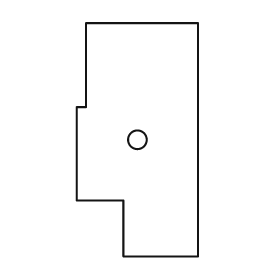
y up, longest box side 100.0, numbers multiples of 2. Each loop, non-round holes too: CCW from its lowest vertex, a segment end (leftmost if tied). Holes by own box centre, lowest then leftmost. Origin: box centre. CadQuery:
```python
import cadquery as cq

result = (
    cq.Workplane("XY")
    .moveTo(-6.0, -50.0)
    .lineTo(26.0, -50.0)
    .lineTo(26.0, 50.0)
    .lineTo(-22.0, 50.0)
    .lineTo(-22.0, 14.0)
    .lineTo(-26.0, 14.0)
    .lineTo(-26.0, -26.0)
    .lineTo(-6.0, -26.0)
    .close()
    .moveTo(0.0, 0.0)
    .circle(4.0)
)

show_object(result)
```